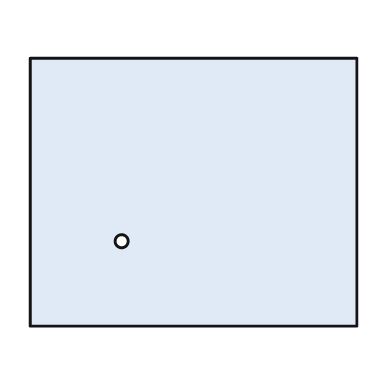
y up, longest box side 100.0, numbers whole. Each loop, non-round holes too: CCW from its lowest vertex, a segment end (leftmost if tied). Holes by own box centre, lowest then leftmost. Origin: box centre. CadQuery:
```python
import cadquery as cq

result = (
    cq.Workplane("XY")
    .moveTo(-50.0, -41.0)
    .lineTo(50.0, -41.0)
    .lineTo(50.0, 41.0)
    .lineTo(-50.0, 41.0)
    .close()
    .moveTo(-22.0, -15.0)
    .circle(2.0)
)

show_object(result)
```